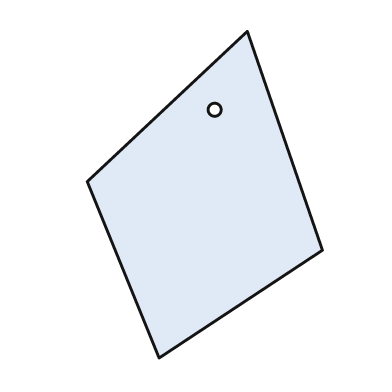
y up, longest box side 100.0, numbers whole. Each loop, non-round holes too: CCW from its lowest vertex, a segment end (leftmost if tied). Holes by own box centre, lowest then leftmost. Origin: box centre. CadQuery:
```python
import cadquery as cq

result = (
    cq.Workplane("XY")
    .moveTo(-14.0, -50.0)
    .lineTo(36.0, -17.0)
    .lineTo(13.0, 50.0)
    .lineTo(-36.0, 4.0)
    .close()
    .moveTo(3.0, 26.0)
    .circle(2.0)
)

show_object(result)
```